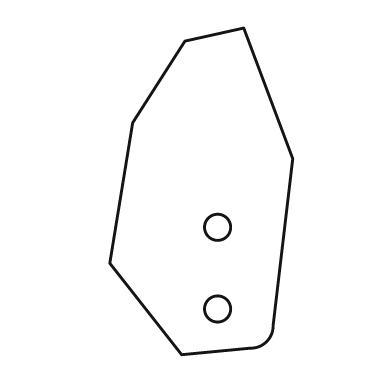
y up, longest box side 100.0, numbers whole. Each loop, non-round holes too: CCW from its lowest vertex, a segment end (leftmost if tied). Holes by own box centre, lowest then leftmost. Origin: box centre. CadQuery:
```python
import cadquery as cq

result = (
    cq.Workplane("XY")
    .moveTo(-6.0, -50.0)
    .lineTo(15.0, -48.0)
    .threePointArc((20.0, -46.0), (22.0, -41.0))
    .lineTo(28.0, 10.0)
    .lineTo(13.0, 50.0)
    .lineTo(-5.0, 46.0)
    .lineTo(-21.0, 21.0)
    .lineTo(-28.0, -22.0)
    .close()
    .moveTo(5.0, -36.0)
    .circle(4.0)
    .moveTo(5.0, -11.0)
    .circle(4.0)
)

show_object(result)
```